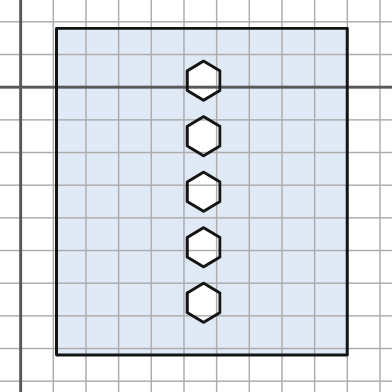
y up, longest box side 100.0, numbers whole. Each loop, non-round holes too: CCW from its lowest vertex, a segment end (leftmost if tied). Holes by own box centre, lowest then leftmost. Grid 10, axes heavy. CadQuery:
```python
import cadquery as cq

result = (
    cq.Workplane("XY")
    .moveTo(11.0, -82.0)
    .lineTo(100.0, -82.0)
    .lineTo(100.0, 18.0)
    .lineTo(11.0, 18.0)
    .close()
    .moveTo(56.0, -72.0)
    .lineTo(61.0, -69.0)
    .lineTo(61.0, -63.0)
    .lineTo(56.0, -60.0)
    .lineTo(51.0, -63.0)
    .lineTo(51.0, -69.0)
    .close()
    .moveTo(56.0, -55.0)
    .lineTo(61.0, -52.0)
    .lineTo(61.0, -46.0)
    .lineTo(56.0, -43.0)
    .lineTo(51.0, -46.0)
    .lineTo(51.0, -52.0)
    .close()
    .moveTo(56.0, -38.0)
    .lineTo(61.0, -35.0)
    .lineTo(61.0, -29.0)
    .lineTo(56.0, -26.0)
    .lineTo(51.0, -29.0)
    .lineTo(51.0, -35.0)
    .close()
    .moveTo(56.0, -21.0)
    .lineTo(61.0, -18.0)
    .lineTo(61.0, -12.0)
    .lineTo(56.0, -9.0)
    .lineTo(51.0, -12.0)
    .lineTo(51.0, -18.0)
    .close()
    .moveTo(56.0, -4.0)
    .lineTo(61.0, -1.0)
    .lineTo(61.0, 5.0)
    .lineTo(56.0, 8.0)
    .lineTo(51.0, 5.0)
    .lineTo(51.0, -1.0)
    .close()
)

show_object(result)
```